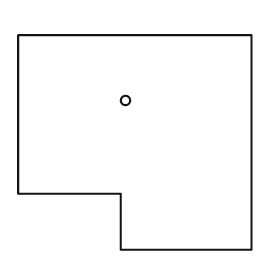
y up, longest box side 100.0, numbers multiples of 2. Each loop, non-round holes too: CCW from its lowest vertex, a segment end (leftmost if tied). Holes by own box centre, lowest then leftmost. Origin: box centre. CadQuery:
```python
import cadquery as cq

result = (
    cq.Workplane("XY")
    .moveTo(-6.0, -46.0)
    .lineTo(50.0, -46.0)
    .lineTo(50.0, 46.0)
    .lineTo(-50.0, 46.0)
    .lineTo(-50.0, -22.0)
    .lineTo(-6.0, -22.0)
    .close()
    .moveTo(-4.0, 18.0)
    .circle(2.0)
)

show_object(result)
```